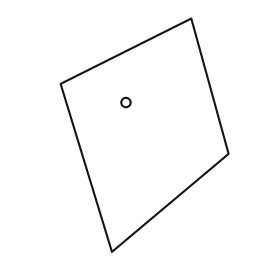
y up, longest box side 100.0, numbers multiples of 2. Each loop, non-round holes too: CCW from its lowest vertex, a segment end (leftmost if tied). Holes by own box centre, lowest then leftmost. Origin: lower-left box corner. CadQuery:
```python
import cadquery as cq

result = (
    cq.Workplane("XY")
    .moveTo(22.0, 0.0)
    .lineTo(72.0, 42.0)
    .lineTo(56.0, 100.0)
    .lineTo(0.0, 72.0)
    .close()
    .moveTo(28.0, 64.0)
    .circle(2.0)
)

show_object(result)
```